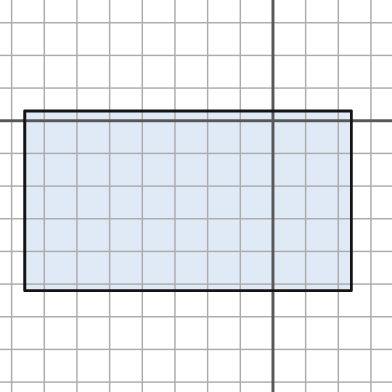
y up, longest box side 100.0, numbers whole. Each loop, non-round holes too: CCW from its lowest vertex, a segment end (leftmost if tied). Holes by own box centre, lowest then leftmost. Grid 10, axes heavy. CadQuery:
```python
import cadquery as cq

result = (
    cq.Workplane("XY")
    .moveTo(-76.0, -52.0)
    .lineTo(24.0, -52.0)
    .lineTo(24.0, 3.0)
    .lineTo(-76.0, 3.0)
    .close()
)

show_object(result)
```